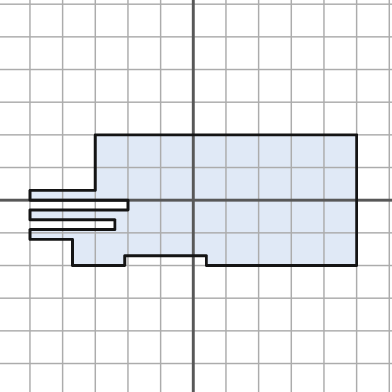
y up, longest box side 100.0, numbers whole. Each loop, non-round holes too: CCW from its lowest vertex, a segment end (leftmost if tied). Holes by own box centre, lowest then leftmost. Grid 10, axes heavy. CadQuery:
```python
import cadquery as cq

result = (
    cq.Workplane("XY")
    .moveTo(-37.0, -20.0)
    .lineTo(-21.0, -20.0)
    .lineTo(-21.0, -17.0)
    .lineTo(4.0, -17.0)
    .lineTo(4.0, -20.0)
    .lineTo(50.0, -20.0)
    .lineTo(50.0, 20.0)
    .lineTo(-30.0, 20.0)
    .lineTo(-30.0, 3.0)
    .lineTo(-50.0, 3.0)
    .lineTo(-50.0, 0.0)
    .lineTo(-20.0, 0.0)
    .lineTo(-20.0, -3.0)
    .lineTo(-50.0, -3.0)
    .lineTo(-50.0, -6.0)
    .lineTo(-24.0, -6.0)
    .lineTo(-24.0, -9.0)
    .lineTo(-50.0, -9.0)
    .lineTo(-50.0, -12.0)
    .lineTo(-37.0, -12.0)
    .close()
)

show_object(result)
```